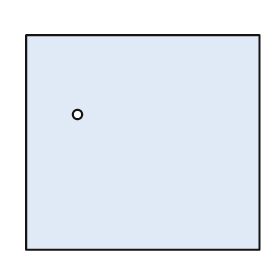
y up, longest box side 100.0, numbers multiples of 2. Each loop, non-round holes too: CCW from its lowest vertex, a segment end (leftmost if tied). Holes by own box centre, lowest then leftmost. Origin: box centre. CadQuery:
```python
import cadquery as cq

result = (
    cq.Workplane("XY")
    .moveTo(-50.0, -46.0)
    .lineTo(50.0, -46.0)
    .lineTo(50.0, 46.0)
    .lineTo(-50.0, 46.0)
    .close()
    .moveTo(-28.0, 12.0)
    .circle(2.0)
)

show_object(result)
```